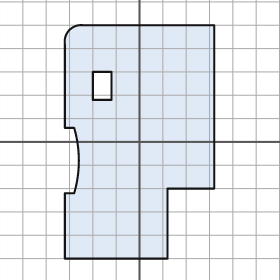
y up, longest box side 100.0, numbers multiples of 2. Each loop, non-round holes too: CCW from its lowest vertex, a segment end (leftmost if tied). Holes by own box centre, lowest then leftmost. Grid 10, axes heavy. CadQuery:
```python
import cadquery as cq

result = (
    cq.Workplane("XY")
    .moveTo(-32.0, -50.0)
    .lineTo(12.0, -50.0)
    .lineTo(12.0, -20.0)
    .lineTo(32.0, -20.0)
    .lineTo(32.0, 50.0)
    .lineTo(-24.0, 50.0)
    .threePointArc((-30.0, 48.0), (-32.0, 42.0))
    .lineTo(-32.0, 6.0)
    .lineTo(-28.0, 6.0)
    .threePointArc((-26.0, -8.0), (-28.0, -22.0))
    .lineTo(-32.0, -22.0)
    .close()
    .moveTo(-20.0, 18.0)
    .lineTo(-12.0, 18.0)
    .lineTo(-12.0, 30.0)
    .lineTo(-20.0, 30.0)
    .close()
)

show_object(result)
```